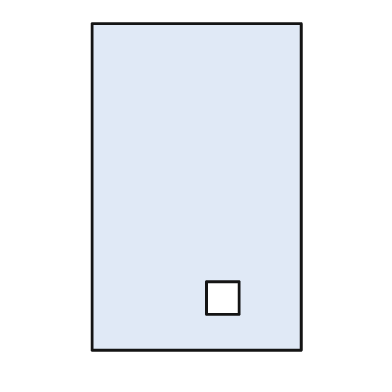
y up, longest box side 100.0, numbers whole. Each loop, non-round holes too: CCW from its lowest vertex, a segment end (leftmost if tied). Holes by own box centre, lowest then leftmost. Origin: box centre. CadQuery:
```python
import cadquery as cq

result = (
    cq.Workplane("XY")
    .moveTo(-32.0, -50.0)
    .lineTo(32.0, -50.0)
    .lineTo(32.0, 50.0)
    .lineTo(-32.0, 50.0)
    .close()
    .moveTo(3.0, -39.0)
    .lineTo(13.0, -39.0)
    .lineTo(13.0, -29.0)
    .lineTo(3.0, -29.0)
    .close()
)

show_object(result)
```